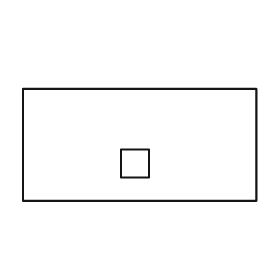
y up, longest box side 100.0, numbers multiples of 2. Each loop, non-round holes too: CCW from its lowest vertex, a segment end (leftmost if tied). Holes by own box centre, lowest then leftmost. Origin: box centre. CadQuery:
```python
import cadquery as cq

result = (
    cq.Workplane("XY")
    .moveTo(-50.0, -24.0)
    .lineTo(50.0, -24.0)
    .lineTo(50.0, 24.0)
    .lineTo(-50.0, 24.0)
    .close()
    .moveTo(-8.0, -14.0)
    .lineTo(4.0, -14.0)
    .lineTo(4.0, -2.0)
    .lineTo(-8.0, -2.0)
    .close()
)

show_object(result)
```